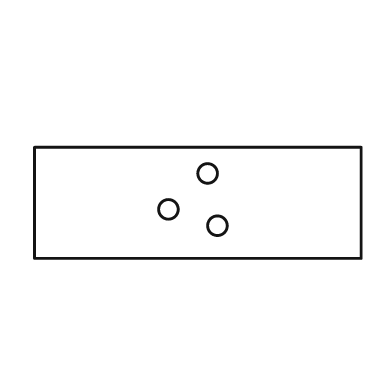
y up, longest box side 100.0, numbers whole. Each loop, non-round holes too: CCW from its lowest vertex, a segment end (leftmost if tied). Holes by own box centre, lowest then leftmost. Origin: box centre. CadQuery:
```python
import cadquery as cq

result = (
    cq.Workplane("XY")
    .moveTo(-50.0, -17.0)
    .lineTo(50.0, -17.0)
    .lineTo(50.0, 17.0)
    .lineTo(-50.0, 17.0)
    .close()
    .moveTo(6.0, -7.0)
    .circle(3.0)
    .moveTo(-9.0, -2.0)
    .circle(3.0)
    .moveTo(3.0, 9.0)
    .circle(3.0)
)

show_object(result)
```